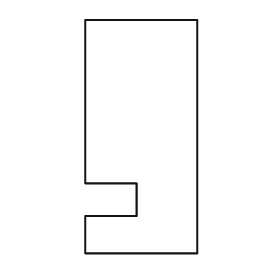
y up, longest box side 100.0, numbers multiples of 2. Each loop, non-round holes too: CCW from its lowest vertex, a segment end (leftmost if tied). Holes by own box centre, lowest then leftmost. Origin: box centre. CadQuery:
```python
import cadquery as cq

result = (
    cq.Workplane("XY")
    .moveTo(-24.0, -50.0)
    .lineTo(24.0, -50.0)
    .lineTo(24.0, 50.0)
    .lineTo(-24.0, 50.0)
    .lineTo(-24.0, -20.0)
    .lineTo(-2.0, -20.0)
    .lineTo(-2.0, -34.0)
    .lineTo(-24.0, -34.0)
    .close()
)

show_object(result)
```